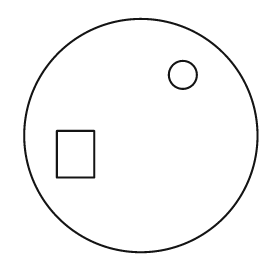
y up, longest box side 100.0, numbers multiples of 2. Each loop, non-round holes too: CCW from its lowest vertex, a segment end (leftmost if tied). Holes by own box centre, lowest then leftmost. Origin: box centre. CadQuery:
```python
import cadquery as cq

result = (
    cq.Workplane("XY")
    .moveTo(0.0, 0.0)
    .circle(50.0)
    .moveTo(-36.0, -18.0)
    .lineTo(-20.0, -18.0)
    .lineTo(-20.0, 2.0)
    .lineTo(-36.0, 2.0)
    .close()
    .moveTo(18.0, 26.0)
    .circle(6.0)
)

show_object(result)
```